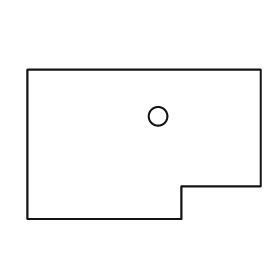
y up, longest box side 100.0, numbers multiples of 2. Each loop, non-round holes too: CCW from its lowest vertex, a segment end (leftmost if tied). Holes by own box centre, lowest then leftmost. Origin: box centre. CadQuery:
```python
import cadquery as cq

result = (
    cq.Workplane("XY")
    .moveTo(-50.0, -32.0)
    .lineTo(16.0, -32.0)
    .lineTo(16.0, -18.0)
    .lineTo(50.0, -18.0)
    .lineTo(50.0, 32.0)
    .lineTo(-50.0, 32.0)
    .close()
    .moveTo(6.0, 12.0)
    .circle(4.0)
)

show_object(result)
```